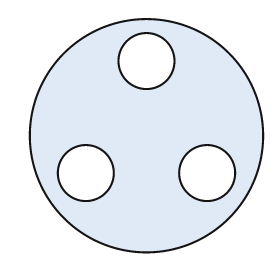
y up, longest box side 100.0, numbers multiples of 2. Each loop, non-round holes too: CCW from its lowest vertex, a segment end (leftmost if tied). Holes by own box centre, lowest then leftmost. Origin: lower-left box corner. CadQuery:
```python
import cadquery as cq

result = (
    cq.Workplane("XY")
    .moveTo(50.0, 50.0)
    .circle(50.0)
    .moveTo(24.0, 34.0)
    .circle(12.0)
    .moveTo(76.0, 34.0)
    .circle(12.0)
    .moveTo(50.0, 82.0)
    .circle(12.0)
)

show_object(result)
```